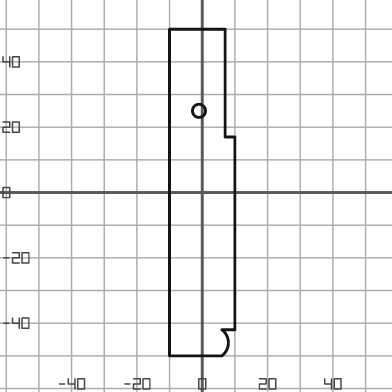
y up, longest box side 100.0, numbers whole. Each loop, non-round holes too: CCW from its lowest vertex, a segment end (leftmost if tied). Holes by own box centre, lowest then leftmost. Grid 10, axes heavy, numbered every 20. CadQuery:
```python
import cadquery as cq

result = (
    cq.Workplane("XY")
    .moveTo(-10.0, -50.0)
    .lineTo(6.0, -50.0)
    .threePointArc((8.0, -46.0), (6.0, -42.0))
    .lineTo(10.0, -42.0)
    .lineTo(10.0, 17.0)
    .lineTo(7.0, 17.0)
    .lineTo(7.0, 50.0)
    .lineTo(-10.0, 50.0)
    .close()
    .moveTo(-1.0, 25.0)
    .circle(2.0)
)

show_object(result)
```